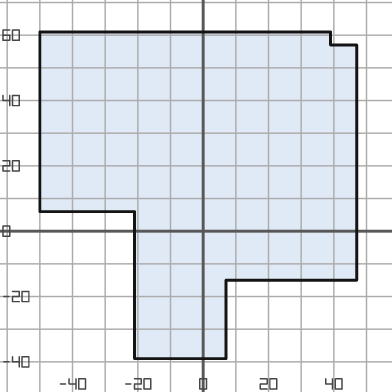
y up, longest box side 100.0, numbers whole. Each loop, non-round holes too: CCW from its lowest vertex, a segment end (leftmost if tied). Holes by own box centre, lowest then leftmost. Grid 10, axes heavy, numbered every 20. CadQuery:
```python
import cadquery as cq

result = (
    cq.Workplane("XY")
    .moveTo(-21.0, -39.0)
    .lineTo(7.0, -39.0)
    .lineTo(7.0, -15.0)
    .lineTo(47.0, -15.0)
    .lineTo(47.0, 57.0)
    .lineTo(39.0, 57.0)
    .lineTo(39.0, 61.0)
    .lineTo(-50.0, 61.0)
    .lineTo(-50.0, 6.0)
    .lineTo(-21.0, 6.0)
    .close()
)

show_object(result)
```